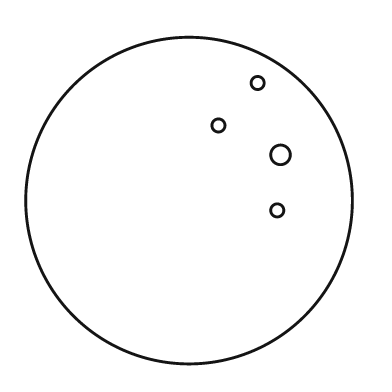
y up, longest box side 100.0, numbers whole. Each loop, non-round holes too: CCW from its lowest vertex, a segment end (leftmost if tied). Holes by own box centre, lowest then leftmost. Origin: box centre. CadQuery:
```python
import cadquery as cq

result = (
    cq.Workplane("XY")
    .moveTo(0.0, 0.0)
    .circle(50.0)
    .moveTo(27.0, -3.0)
    .circle(2.0)
    .moveTo(28.0, 14.0)
    .circle(3.0)
    .moveTo(9.0, 23.0)
    .circle(2.0)
    .moveTo(21.0, 36.0)
    .circle(2.0)
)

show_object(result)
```